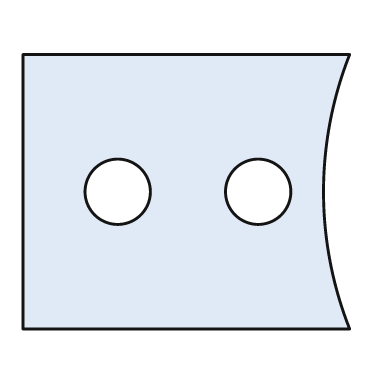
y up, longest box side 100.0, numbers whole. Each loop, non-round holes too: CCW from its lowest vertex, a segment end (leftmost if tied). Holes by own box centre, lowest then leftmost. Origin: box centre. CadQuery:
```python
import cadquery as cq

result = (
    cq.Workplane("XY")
    .moveTo(-50.0, -42.0)
    .lineTo(50.0, -42.0)
    .threePointArc((42.0, 0.0), (50.0, 42.0))
    .lineTo(-50.0, 42.0)
    .close()
    .moveTo(-21.0, 0.0)
    .circle(10.0)
    .moveTo(22.0, 0.0)
    .circle(10.0)
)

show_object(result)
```